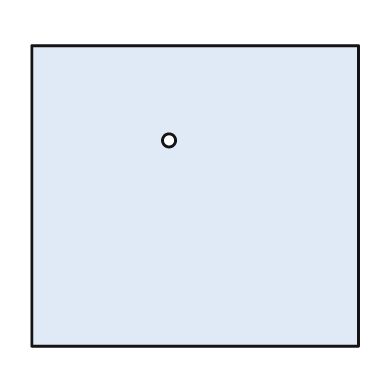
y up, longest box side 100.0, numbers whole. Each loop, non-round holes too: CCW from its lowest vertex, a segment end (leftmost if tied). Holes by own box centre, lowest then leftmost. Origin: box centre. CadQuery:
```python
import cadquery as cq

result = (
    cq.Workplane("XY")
    .moveTo(-50.0, -46.0)
    .lineTo(50.0, -46.0)
    .lineTo(50.0, 46.0)
    .lineTo(-50.0, 46.0)
    .close()
    .moveTo(-8.0, 17.0)
    .circle(2.0)
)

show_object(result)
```